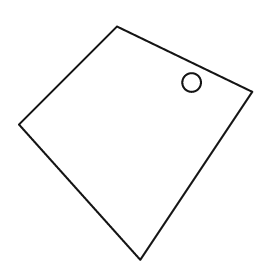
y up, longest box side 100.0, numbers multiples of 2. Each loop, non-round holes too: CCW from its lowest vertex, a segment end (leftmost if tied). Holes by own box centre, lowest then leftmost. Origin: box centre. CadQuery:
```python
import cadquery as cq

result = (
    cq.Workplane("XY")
    .moveTo(2.0, -50.0)
    .lineTo(50.0, 22.0)
    .lineTo(-8.0, 50.0)
    .lineTo(-50.0, 8.0)
    .close()
    .moveTo(24.0, 26.0)
    .circle(4.0)
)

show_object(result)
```